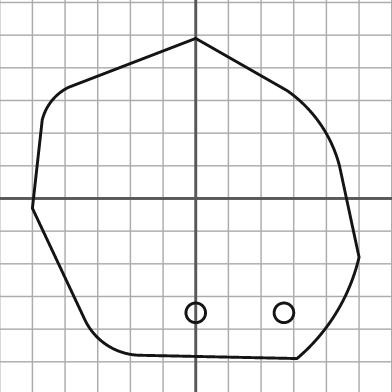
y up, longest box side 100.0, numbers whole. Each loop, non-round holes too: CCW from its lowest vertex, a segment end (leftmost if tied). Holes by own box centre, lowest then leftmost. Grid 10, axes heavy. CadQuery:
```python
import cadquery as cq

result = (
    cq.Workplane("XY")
    .moveTo(31.0, -49.0)
    .threePointArc((43.0, -35.0), (50.0, -18.0))
    .lineTo(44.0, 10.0)
    .threePointArc((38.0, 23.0), (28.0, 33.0))
    .lineTo(0.0, 49.0)
    .lineTo(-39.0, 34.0)
    .threePointArc((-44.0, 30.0), (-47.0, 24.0))
    .lineTo(-50.0, -3.0)
    .lineTo(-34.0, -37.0)
    .threePointArc((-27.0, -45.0), (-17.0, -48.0))
    .close()
    .moveTo(0.0, -35.0)
    .circle(3.0)
    .moveTo(27.0, -35.0)
    .circle(3.0)
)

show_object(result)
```